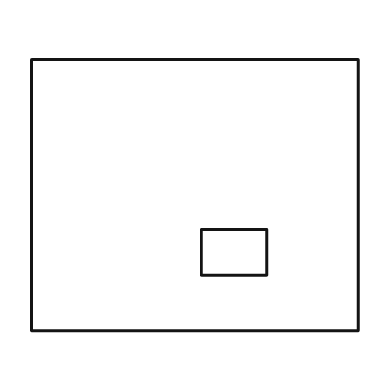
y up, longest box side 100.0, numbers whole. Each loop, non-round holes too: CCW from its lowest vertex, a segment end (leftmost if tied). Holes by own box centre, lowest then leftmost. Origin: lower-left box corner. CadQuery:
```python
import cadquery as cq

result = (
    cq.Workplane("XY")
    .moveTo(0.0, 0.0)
    .lineTo(100.0, 0.0)
    .lineTo(100.0, 83.0)
    .lineTo(0.0, 83.0)
    .close()
    .moveTo(52.0, 17.0)
    .lineTo(72.0, 17.0)
    .lineTo(72.0, 31.0)
    .lineTo(52.0, 31.0)
    .close()
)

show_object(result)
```